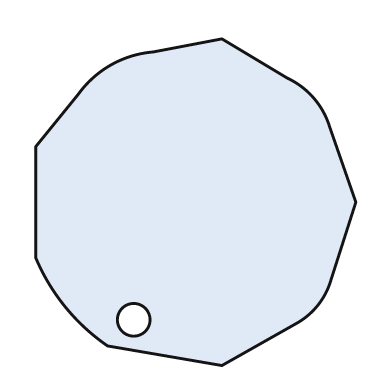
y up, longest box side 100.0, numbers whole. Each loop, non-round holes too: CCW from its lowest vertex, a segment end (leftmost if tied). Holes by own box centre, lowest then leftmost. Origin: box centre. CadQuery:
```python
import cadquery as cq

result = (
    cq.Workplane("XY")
    .moveTo(8.0, -50.0)
    .lineTo(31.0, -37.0)
    .threePointArc((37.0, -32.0), (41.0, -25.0))
    .lineTo(49.0, 0.0)
    .lineTo(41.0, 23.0)
    .threePointArc((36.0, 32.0), (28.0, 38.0))
    .lineTo(8.0, 50.0)
    .lineTo(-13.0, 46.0)
    .threePointArc((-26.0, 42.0), (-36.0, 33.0))
    .lineTo(-49.0, 17.0)
    .lineTo(-49.0, -17.0)
    .threePointArc((-40.0, -32.0), (-27.0, -44.0))
    .close()
    .moveTo(-19.0, -36.0)
    .circle(5.0)
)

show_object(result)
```